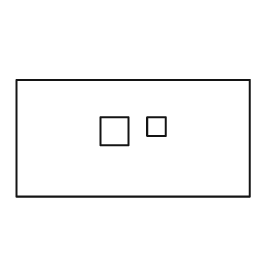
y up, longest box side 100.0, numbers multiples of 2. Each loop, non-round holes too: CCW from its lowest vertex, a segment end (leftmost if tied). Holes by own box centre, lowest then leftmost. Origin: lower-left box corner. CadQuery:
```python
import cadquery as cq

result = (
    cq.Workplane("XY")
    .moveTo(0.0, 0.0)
    .lineTo(100.0, 0.0)
    .lineTo(100.0, 50.0)
    .lineTo(0.0, 50.0)
    .close()
    .moveTo(36.0, 22.0)
    .lineTo(48.0, 22.0)
    .lineTo(48.0, 34.0)
    .lineTo(36.0, 34.0)
    .close()
    .moveTo(56.0, 26.0)
    .lineTo(64.0, 26.0)
    .lineTo(64.0, 34.0)
    .lineTo(56.0, 34.0)
    .close()
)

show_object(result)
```